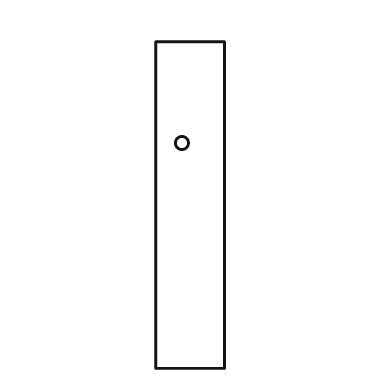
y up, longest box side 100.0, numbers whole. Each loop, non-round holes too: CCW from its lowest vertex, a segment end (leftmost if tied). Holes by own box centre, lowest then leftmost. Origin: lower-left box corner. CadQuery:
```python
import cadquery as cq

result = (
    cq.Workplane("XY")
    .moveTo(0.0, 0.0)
    .lineTo(21.0, 0.0)
    .lineTo(21.0, 100.0)
    .lineTo(0.0, 100.0)
    .close()
    .moveTo(8.0, 69.0)
    .circle(2.0)
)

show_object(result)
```